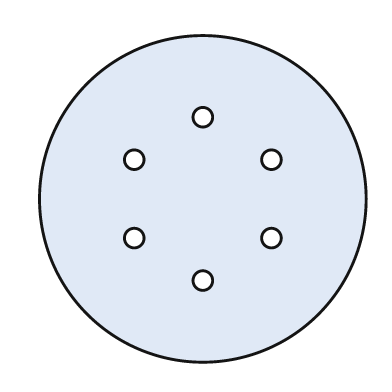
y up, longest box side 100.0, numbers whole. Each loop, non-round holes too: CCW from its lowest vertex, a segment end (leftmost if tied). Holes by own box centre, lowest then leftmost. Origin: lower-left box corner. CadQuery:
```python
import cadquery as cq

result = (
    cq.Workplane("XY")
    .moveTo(50.0, 50.0)
    .circle(50.0)
    .moveTo(50.0, 25.0)
    .circle(3.0)
    .moveTo(29.0, 38.0)
    .circle(3.0)
    .moveTo(71.0, 38.0)
    .circle(3.0)
    .moveTo(29.0, 62.0)
    .circle(3.0)
    .moveTo(71.0, 62.0)
    .circle(3.0)
    .moveTo(50.0, 75.0)
    .circle(3.0)
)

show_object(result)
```